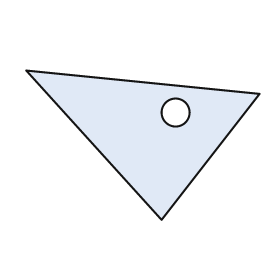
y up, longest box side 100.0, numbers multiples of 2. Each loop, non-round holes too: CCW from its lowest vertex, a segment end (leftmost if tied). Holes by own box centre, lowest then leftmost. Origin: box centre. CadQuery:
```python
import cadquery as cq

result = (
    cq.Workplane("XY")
    .moveTo(8.0, -32.0)
    .lineTo(50.0, 22.0)
    .lineTo(-50.0, 32.0)
    .close()
    .moveTo(14.0, 14.0)
    .circle(6.0)
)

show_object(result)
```